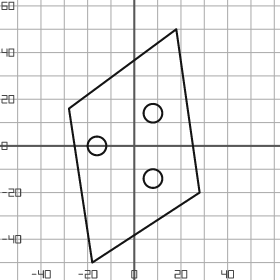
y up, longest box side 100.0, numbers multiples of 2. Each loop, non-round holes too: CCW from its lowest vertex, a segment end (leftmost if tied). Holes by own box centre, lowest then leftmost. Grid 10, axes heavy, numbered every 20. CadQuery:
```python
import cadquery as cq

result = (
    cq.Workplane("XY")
    .moveTo(-18.0, -50.0)
    .lineTo(28.0, -20.0)
    .lineTo(18.0, 50.0)
    .lineTo(-28.0, 16.0)
    .close()
    .moveTo(8.0, -14.0)
    .circle(4.0)
    .moveTo(-16.0, 0.0)
    .circle(4.0)
    .moveTo(8.0, 14.0)
    .circle(4.0)
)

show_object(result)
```